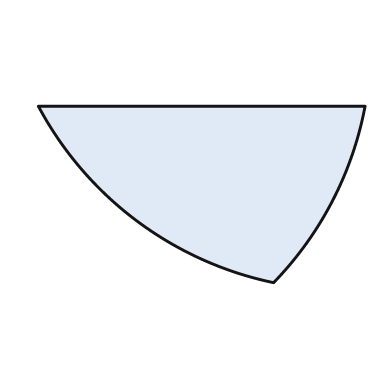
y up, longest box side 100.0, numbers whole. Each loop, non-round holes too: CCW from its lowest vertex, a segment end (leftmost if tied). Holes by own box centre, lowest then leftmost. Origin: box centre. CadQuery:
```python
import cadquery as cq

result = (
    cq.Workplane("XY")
    .moveTo(22.0, -27.0)
    .threePointArc((40.0, -2.0), (50.0, 27.0))
    .lineTo(-50.0, 27.0)
    .threePointArc((-20.0, -8.0), (22.0, -27.0))
    .close()
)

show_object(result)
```